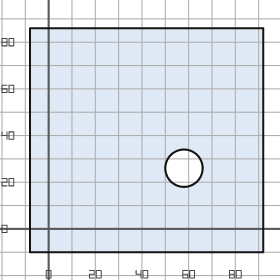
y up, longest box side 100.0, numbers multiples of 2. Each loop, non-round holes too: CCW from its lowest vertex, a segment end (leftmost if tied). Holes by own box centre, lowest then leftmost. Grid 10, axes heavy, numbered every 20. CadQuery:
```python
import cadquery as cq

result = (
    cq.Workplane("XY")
    .moveTo(-8.0, -10.0)
    .lineTo(92.0, -10.0)
    .lineTo(92.0, 86.0)
    .lineTo(-8.0, 86.0)
    .close()
    .moveTo(58.0, 26.0)
    .circle(8.0)
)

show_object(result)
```